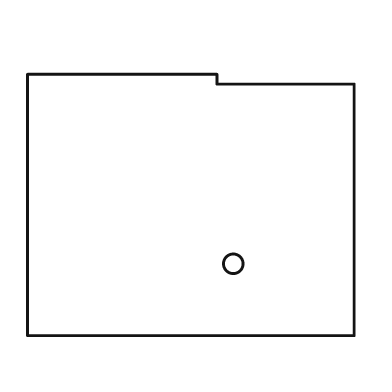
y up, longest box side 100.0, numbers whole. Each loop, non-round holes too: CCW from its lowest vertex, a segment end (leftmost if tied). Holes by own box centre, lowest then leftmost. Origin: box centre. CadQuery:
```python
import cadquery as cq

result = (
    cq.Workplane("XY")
    .moveTo(-50.0, -40.0)
    .lineTo(50.0, -40.0)
    .lineTo(50.0, 37.0)
    .lineTo(8.0, 37.0)
    .lineTo(8.0, 40.0)
    .lineTo(-50.0, 40.0)
    .close()
    .moveTo(13.0, -18.0)
    .circle(3.0)
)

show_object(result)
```